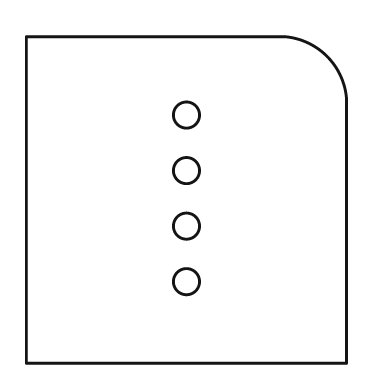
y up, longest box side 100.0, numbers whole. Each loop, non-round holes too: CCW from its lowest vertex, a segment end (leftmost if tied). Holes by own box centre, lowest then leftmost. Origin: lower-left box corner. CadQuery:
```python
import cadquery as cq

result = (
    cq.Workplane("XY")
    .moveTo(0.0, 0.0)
    .lineTo(98.0, 0.0)
    .lineTo(98.0, 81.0)
    .threePointArc((92.0, 94.0), (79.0, 100.0))
    .lineTo(0.0, 100.0)
    .close()
    .moveTo(49.0, 25.0)
    .circle(4.0)
    .moveTo(49.0, 42.0)
    .circle(4.0)
    .moveTo(49.0, 59.0)
    .circle(4.0)
    .moveTo(49.0, 76.0)
    .circle(4.0)
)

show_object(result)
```